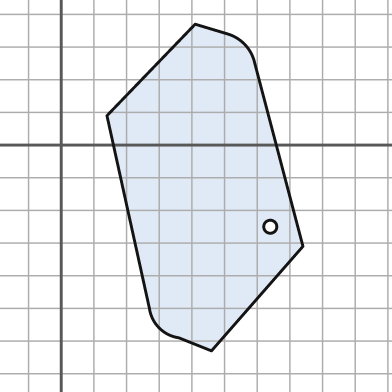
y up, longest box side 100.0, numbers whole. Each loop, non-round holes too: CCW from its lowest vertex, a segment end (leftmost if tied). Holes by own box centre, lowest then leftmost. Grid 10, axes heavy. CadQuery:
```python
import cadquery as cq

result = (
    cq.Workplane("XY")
    .moveTo(46.0, -63.0)
    .lineTo(74.0, -31.0)
    .lineTo(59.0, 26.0)
    .threePointArc((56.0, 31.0), (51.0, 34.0))
    .lineTo(41.0, 37.0)
    .lineTo(14.0, 9.0)
    .lineTo(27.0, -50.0)
    .threePointArc((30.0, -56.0), (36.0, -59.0))
    .close()
    .moveTo(64.0, -25.0)
    .circle(2.0)
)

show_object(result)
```